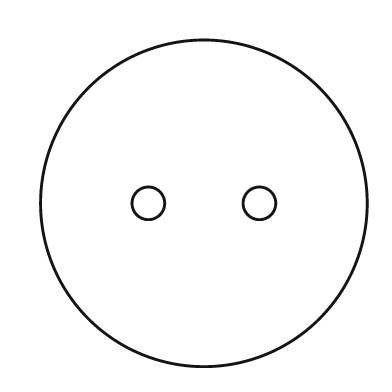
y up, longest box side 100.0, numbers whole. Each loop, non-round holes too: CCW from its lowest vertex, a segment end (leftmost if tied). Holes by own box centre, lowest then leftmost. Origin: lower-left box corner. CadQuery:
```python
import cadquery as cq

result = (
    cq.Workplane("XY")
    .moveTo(50.0, 50.0)
    .circle(50.0)
    .moveTo(33.0, 50.0)
    .circle(5.0)
    .moveTo(67.0, 50.0)
    .circle(5.0)
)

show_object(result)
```